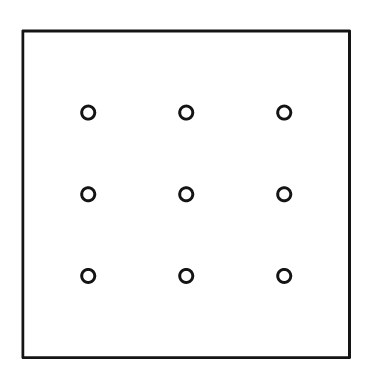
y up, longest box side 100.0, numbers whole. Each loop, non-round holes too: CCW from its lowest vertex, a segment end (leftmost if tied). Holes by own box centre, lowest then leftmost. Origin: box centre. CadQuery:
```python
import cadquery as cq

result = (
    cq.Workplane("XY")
    .moveTo(-50.0, -50.0)
    .lineTo(50.0, -50.0)
    .lineTo(50.0, 50.0)
    .lineTo(-50.0, 50.0)
    .close()
    .moveTo(-30.0, -25.0)
    .circle(2.0)
    .moveTo(0.0, -25.0)
    .circle(2.0)
    .moveTo(30.0, -25.0)
    .circle(2.0)
    .moveTo(-30.0, 0.0)
    .circle(2.0)
    .moveTo(0.0, 0.0)
    .circle(2.0)
    .moveTo(30.0, 0.0)
    .circle(2.0)
    .moveTo(-30.0, 25.0)
    .circle(2.0)
    .moveTo(0.0, 25.0)
    .circle(2.0)
    .moveTo(30.0, 25.0)
    .circle(2.0)
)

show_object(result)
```